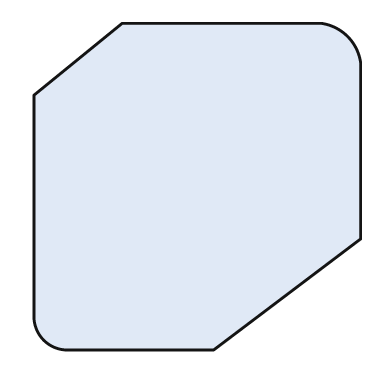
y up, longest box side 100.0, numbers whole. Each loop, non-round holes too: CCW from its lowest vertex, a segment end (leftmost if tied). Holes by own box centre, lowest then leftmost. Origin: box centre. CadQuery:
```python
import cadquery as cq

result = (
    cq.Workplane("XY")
    .moveTo(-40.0, -50.0)
    .lineTo(5.0, -50.0)
    .lineTo(50.0, -16.0)
    .lineTo(50.0, 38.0)
    .threePointArc((46.0, 46.0), (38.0, 50.0))
    .lineTo(-23.0, 50.0)
    .lineTo(-50.0, 28.0)
    .lineTo(-50.0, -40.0)
    .threePointArc((-47.0, -47.0), (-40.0, -50.0))
    .close()
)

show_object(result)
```